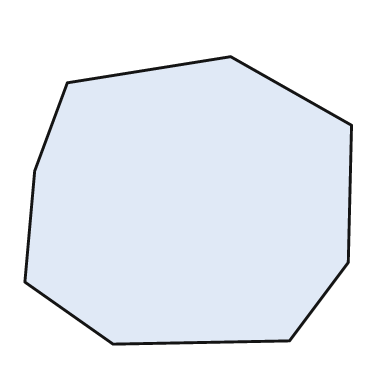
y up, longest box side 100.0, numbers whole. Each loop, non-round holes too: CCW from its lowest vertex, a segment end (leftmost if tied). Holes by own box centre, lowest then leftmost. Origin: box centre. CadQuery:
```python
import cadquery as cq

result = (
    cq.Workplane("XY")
    .moveTo(-23.0, -44.0)
    .lineTo(31.0, -43.0)
    .lineTo(49.0, -19.0)
    .lineTo(50.0, 23.0)
    .lineTo(13.0, 44.0)
    .lineTo(-37.0, 36.0)
    .lineTo(-47.0, 9.0)
    .lineTo(-50.0, -25.0)
    .close()
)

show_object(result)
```